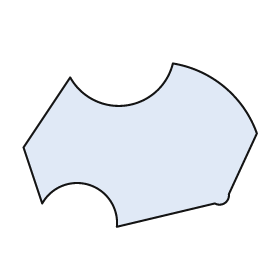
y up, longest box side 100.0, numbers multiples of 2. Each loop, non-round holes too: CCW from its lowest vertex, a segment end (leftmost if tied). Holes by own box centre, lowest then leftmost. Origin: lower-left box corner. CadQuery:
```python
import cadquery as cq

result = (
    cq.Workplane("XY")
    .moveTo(40.0, 0.0)
    .lineTo(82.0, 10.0)
    .threePointArc((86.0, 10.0), (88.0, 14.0))
    .lineTo(100.0, 40.0)
    .threePointArc((86.0, 60.0), (64.0, 70.0))
    .threePointArc((44.0, 52.0), (20.0, 64.0))
    .lineTo(0.0, 34.0)
    .lineTo(8.0, 10.0)
    .threePointArc((28.0, 18.0), (40.0, 0.0))
    .close()
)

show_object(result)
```